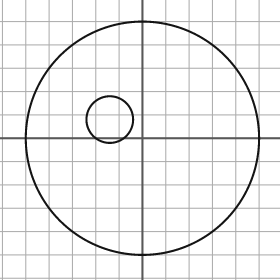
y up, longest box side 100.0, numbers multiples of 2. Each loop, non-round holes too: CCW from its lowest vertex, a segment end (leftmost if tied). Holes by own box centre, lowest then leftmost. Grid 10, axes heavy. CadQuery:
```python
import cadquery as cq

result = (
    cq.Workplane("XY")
    .moveTo(0.0, 0.0)
    .circle(50.0)
    .moveTo(-14.0, 8.0)
    .circle(10.0)
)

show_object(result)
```